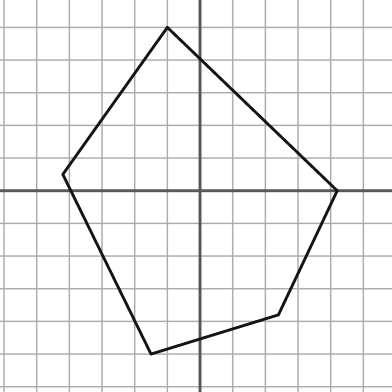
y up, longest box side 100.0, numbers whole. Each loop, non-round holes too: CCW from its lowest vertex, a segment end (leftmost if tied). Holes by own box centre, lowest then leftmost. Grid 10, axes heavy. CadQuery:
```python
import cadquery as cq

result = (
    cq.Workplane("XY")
    .moveTo(-15.0, -50.0)
    .lineTo(24.0, -38.0)
    .lineTo(42.0, 0.0)
    .lineTo(-10.0, 50.0)
    .lineTo(-42.0, 5.0)
    .close()
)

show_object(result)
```